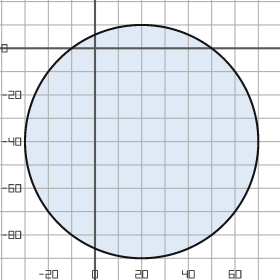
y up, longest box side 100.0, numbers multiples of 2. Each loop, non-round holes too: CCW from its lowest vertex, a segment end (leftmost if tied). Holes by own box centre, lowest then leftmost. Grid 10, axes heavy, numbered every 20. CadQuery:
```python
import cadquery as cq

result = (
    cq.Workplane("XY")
    .moveTo(20.0, -40.0)
    .circle(50.0)
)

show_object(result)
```